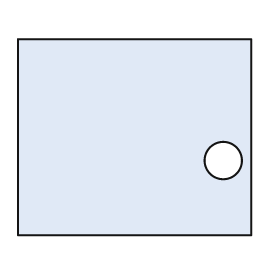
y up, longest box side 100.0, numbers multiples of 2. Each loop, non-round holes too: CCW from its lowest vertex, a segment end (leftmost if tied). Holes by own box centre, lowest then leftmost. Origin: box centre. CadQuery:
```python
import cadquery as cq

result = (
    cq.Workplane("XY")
    .moveTo(-50.0, -42.0)
    .lineTo(50.0, -42.0)
    .lineTo(50.0, 42.0)
    .lineTo(-50.0, 42.0)
    .close()
    .moveTo(38.0, -10.0)
    .circle(8.0)
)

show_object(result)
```